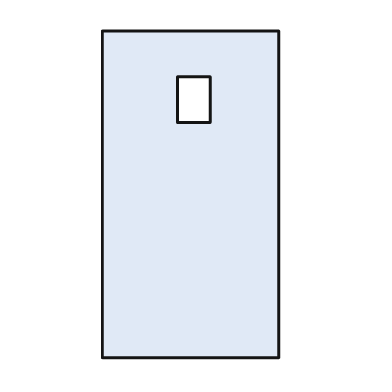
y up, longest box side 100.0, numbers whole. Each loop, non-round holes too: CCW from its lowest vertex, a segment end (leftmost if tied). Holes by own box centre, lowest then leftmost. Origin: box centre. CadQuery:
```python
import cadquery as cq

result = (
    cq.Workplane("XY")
    .moveTo(-27.0, -50.0)
    .lineTo(27.0, -50.0)
    .lineTo(27.0, 50.0)
    .lineTo(-27.0, 50.0)
    .close()
    .moveTo(-4.0, 22.0)
    .lineTo(6.0, 22.0)
    .lineTo(6.0, 36.0)
    .lineTo(-4.0, 36.0)
    .close()
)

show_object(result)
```